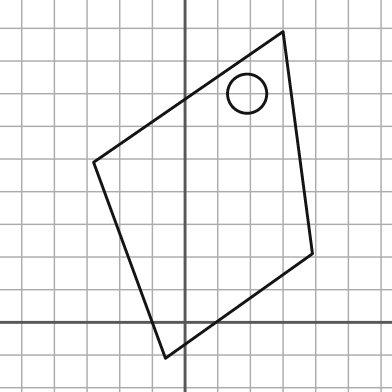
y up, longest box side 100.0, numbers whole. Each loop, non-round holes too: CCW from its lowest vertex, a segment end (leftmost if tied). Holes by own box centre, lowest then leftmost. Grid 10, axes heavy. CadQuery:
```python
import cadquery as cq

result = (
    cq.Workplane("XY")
    .moveTo(-6.0, -11.0)
    .lineTo(39.0, 21.0)
    .lineTo(30.0, 89.0)
    .lineTo(-28.0, 49.0)
    .close()
    .moveTo(19.0, 70.0)
    .circle(6.0)
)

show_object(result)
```